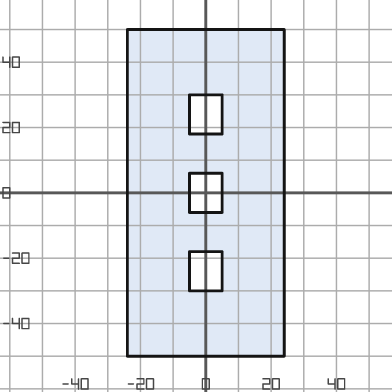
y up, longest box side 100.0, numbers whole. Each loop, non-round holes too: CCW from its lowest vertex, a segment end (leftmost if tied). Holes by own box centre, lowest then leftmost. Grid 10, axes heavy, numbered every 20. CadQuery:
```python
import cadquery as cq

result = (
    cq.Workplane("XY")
    .moveTo(-24.0, -50.0)
    .lineTo(24.0, -50.0)
    .lineTo(24.0, 50.0)
    .lineTo(-24.0, 50.0)
    .close()
    .moveTo(-5.0, -30.0)
    .lineTo(5.0, -30.0)
    .lineTo(5.0, -18.0)
    .lineTo(-5.0, -18.0)
    .close()
    .moveTo(-5.0, -6.0)
    .lineTo(5.0, -6.0)
    .lineTo(5.0, 6.0)
    .lineTo(-5.0, 6.0)
    .close()
    .moveTo(-5.0, 18.0)
    .lineTo(5.0, 18.0)
    .lineTo(5.0, 30.0)
    .lineTo(-5.0, 30.0)
    .close()
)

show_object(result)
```